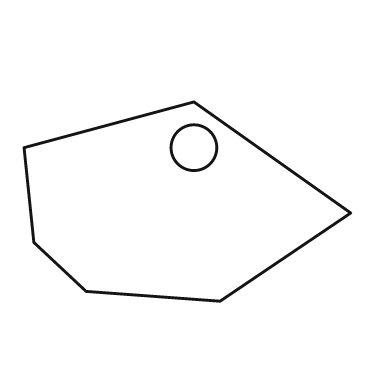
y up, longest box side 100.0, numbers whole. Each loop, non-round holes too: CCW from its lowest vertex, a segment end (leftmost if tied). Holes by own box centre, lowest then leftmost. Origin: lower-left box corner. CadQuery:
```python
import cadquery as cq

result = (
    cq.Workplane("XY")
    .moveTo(60.0, 0.0)
    .lineTo(100.0, 27.0)
    .lineTo(52.0, 61.0)
    .lineTo(0.0, 47.0)
    .lineTo(3.0, 18.0)
    .lineTo(19.0, 3.0)
    .close()
    .moveTo(52.0, 47.0)
    .circle(7.0)
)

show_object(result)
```